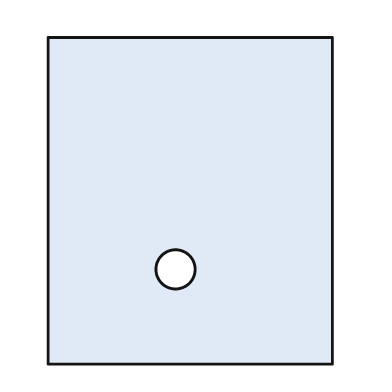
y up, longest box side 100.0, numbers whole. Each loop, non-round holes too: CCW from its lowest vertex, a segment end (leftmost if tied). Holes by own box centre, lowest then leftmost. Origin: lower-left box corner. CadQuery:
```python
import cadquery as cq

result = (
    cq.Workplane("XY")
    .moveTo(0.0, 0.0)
    .lineTo(87.0, 0.0)
    .lineTo(87.0, 100.0)
    .lineTo(0.0, 100.0)
    .close()
    .moveTo(39.0, 29.0)
    .circle(6.0)
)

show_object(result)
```